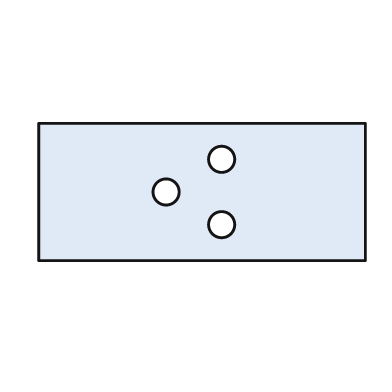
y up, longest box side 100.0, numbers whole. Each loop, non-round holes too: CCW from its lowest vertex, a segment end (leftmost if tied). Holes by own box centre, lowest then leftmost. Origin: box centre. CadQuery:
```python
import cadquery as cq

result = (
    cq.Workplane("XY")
    .moveTo(-50.0, -21.0)
    .lineTo(50.0, -21.0)
    .lineTo(50.0, 21.0)
    .lineTo(-50.0, 21.0)
    .close()
    .moveTo(6.0, -10.0)
    .circle(4.0)
    .moveTo(-11.0, 0.0)
    .circle(4.0)
    .moveTo(6.0, 10.0)
    .circle(4.0)
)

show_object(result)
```